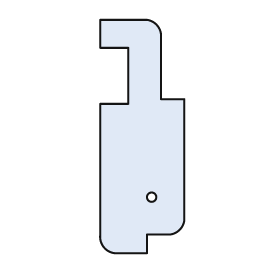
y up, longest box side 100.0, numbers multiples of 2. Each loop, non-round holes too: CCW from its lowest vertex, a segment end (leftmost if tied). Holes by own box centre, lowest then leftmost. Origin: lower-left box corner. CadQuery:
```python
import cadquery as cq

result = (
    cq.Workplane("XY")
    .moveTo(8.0, 0.0)
    .lineTo(20.0, 0.0)
    .lineTo(20.0, 8.0)
    .lineTo(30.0, 8.0)
    .threePointArc((34.0, 10.0), (36.0, 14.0))
    .lineTo(36.0, 66.0)
    .lineTo(26.0, 66.0)
    .lineTo(26.0, 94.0)
    .threePointArc((24.0, 98.0), (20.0, 100.0))
    .lineTo(0.0, 100.0)
    .lineTo(0.0, 88.0)
    .lineTo(12.0, 88.0)
    .lineTo(12.0, 64.0)
    .lineTo(0.0, 64.0)
    .lineTo(0.0, 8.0)
    .threePointArc((2.0, 2.0), (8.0, 0.0))
    .close()
    .moveTo(22.0, 24.0)
    .circle(2.0)
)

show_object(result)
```